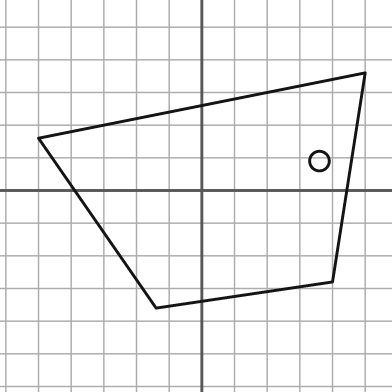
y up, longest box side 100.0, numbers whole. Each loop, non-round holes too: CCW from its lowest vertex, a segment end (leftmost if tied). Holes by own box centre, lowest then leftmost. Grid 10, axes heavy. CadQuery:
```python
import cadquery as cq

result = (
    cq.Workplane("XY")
    .moveTo(-14.0, -36.0)
    .lineTo(40.0, -28.0)
    .lineTo(50.0, 36.0)
    .lineTo(-50.0, 16.0)
    .close()
    .moveTo(36.0, 9.0)
    .circle(3.0)
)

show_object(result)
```